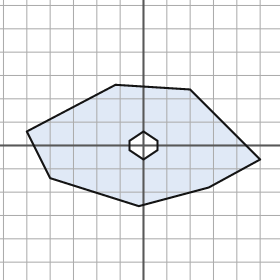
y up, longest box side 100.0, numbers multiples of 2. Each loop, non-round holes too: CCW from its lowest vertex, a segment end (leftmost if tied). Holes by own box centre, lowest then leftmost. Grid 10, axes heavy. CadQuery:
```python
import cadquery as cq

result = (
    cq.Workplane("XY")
    .moveTo(-2.0, -26.0)
    .lineTo(28.0, -18.0)
    .lineTo(50.0, -6.0)
    .lineTo(20.0, 24.0)
    .lineTo(-12.0, 26.0)
    .lineTo(-50.0, 6.0)
    .lineTo(-40.0, -14.0)
    .close()
    .moveTo(0.0, -6.0)
    .lineTo(6.0, -2.0)
    .lineTo(6.0, 2.0)
    .lineTo(0.0, 6.0)
    .lineTo(-6.0, 2.0)
    .lineTo(-6.0, -2.0)
    .close()
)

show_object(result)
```